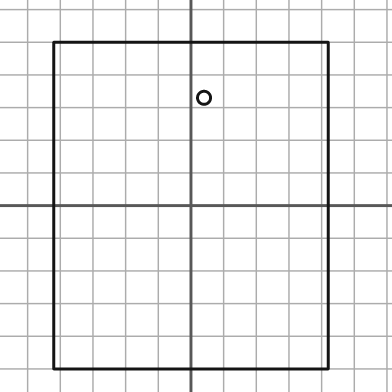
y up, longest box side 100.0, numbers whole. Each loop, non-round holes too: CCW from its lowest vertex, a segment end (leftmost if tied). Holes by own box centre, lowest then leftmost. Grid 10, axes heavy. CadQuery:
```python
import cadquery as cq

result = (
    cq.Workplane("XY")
    .moveTo(-42.0, -50.0)
    .lineTo(42.0, -50.0)
    .lineTo(42.0, 50.0)
    .lineTo(-42.0, 50.0)
    .close()
    .moveTo(4.0, 33.0)
    .circle(2.0)
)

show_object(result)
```